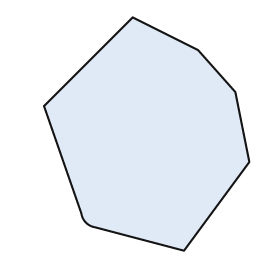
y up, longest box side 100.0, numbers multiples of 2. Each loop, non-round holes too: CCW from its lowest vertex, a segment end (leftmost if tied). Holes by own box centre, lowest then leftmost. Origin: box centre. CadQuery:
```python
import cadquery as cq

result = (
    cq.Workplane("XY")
    .moveTo(16.0, -50.0)
    .lineTo(44.0, -12.0)
    .lineTo(38.0, 18.0)
    .lineTo(22.0, 36.0)
    .lineTo(-6.0, 50.0)
    .lineTo(-44.0, 12.0)
    .lineTo(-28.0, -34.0)
    .threePointArc((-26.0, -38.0), (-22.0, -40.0))
    .close()
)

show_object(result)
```